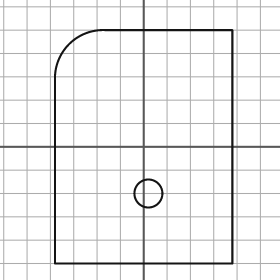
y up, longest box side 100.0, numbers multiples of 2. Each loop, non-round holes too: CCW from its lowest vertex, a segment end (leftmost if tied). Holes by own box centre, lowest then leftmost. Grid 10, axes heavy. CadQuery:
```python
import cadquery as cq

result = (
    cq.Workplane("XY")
    .moveTo(-38.0, -50.0)
    .lineTo(38.0, -50.0)
    .lineTo(38.0, 50.0)
    .lineTo(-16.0, 50.0)
    .threePointArc((-32.0, 44.0), (-38.0, 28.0))
    .close()
    .moveTo(2.0, -20.0)
    .circle(6.0)
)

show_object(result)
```